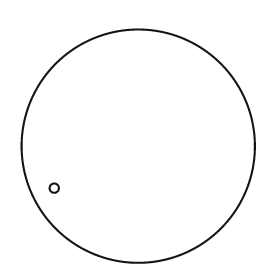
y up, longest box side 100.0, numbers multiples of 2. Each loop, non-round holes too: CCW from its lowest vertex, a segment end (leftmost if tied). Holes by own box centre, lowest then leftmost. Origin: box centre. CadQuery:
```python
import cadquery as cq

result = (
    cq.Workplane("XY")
    .moveTo(0.0, 0.0)
    .circle(50.0)
    .moveTo(-36.0, -18.0)
    .circle(2.0)
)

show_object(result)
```